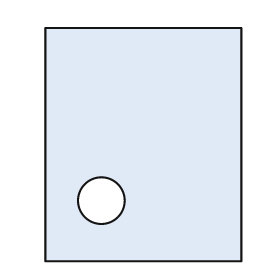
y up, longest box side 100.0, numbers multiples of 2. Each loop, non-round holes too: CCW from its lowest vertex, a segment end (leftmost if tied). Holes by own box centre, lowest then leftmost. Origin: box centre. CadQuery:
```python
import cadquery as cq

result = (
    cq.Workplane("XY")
    .moveTo(-42.0, -50.0)
    .lineTo(42.0, -50.0)
    .lineTo(42.0, 50.0)
    .lineTo(-42.0, 50.0)
    .close()
    .moveTo(-18.0, -24.0)
    .circle(10.0)
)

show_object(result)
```